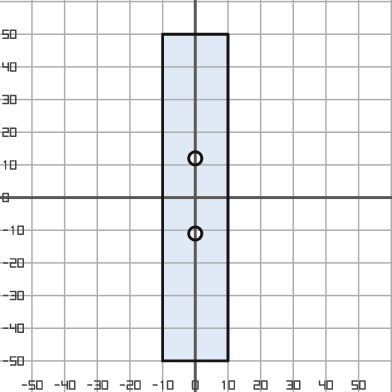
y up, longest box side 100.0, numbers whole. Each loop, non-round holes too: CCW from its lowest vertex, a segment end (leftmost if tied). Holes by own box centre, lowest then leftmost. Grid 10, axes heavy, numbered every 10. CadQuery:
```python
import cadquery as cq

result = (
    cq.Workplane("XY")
    .moveTo(-10.0, -50.0)
    .lineTo(10.0, -50.0)
    .lineTo(10.0, 50.0)
    .lineTo(-10.0, 50.0)
    .close()
    .moveTo(0.0, -11.0)
    .circle(2.0)
    .moveTo(0.0, 12.0)
    .circle(2.0)
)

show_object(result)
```